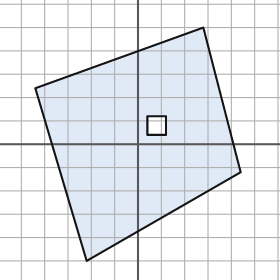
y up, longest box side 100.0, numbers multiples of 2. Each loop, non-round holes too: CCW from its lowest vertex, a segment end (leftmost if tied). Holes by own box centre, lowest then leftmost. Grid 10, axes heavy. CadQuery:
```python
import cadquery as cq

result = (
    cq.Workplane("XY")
    .moveTo(-22.0, -50.0)
    .lineTo(44.0, -12.0)
    .lineTo(28.0, 50.0)
    .lineTo(-44.0, 24.0)
    .close()
    .moveTo(4.0, 4.0)
    .lineTo(12.0, 4.0)
    .lineTo(12.0, 12.0)
    .lineTo(4.0, 12.0)
    .close()
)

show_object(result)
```